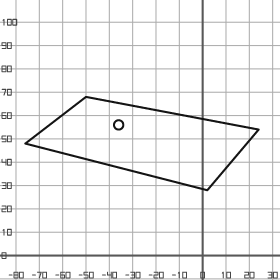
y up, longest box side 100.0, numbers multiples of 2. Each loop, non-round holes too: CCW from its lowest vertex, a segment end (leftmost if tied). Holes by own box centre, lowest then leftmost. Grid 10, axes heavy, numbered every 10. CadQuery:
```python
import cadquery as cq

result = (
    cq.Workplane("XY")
    .moveTo(2.0, 28.0)
    .lineTo(24.0, 54.0)
    .lineTo(-50.0, 68.0)
    .lineTo(-76.0, 48.0)
    .close()
    .moveTo(-36.0, 56.0)
    .circle(2.0)
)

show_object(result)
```